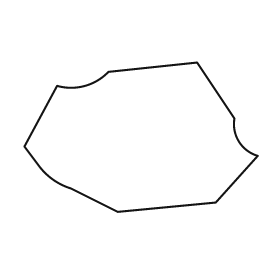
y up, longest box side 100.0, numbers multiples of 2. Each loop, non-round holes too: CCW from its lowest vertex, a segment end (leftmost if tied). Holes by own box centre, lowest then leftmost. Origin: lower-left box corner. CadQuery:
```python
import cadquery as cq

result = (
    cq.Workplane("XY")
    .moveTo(40.0, 0.0)
    .lineTo(82.0, 4.0)
    .lineTo(100.0, 24.0)
    .threePointArc((92.0, 30.0), (90.0, 40.0))
    .lineTo(74.0, 64.0)
    .lineTo(36.0, 60.0)
    .threePointArc((26.0, 54.0), (14.0, 54.0))
    .lineTo(0.0, 28.0)
    .lineTo(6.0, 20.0)
    .threePointArc((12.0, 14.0), (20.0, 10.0))
    .close()
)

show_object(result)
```